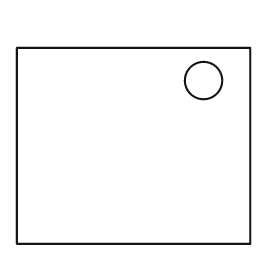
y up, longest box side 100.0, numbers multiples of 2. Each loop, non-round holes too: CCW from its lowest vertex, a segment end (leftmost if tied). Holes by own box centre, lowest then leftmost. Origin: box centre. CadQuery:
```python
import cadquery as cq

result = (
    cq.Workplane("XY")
    .moveTo(-50.0, -42.0)
    .lineTo(50.0, -42.0)
    .lineTo(50.0, 42.0)
    .lineTo(-50.0, 42.0)
    .close()
    .moveTo(30.0, 28.0)
    .circle(8.0)
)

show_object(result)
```